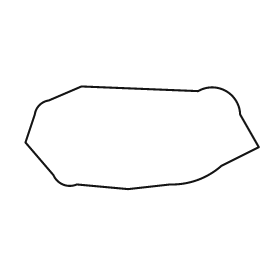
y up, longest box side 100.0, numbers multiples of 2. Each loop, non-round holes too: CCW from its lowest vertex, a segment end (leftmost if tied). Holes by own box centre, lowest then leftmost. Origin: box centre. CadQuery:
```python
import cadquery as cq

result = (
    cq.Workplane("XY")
    .moveTo(-6.0, -22.0)
    .lineTo(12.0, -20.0)
    .threePointArc((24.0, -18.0), (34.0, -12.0))
    .lineTo(50.0, -4.0)
    .lineTo(42.0, 10.0)
    .threePointArc((36.0, 20.0), (24.0, 20.0))
    .lineTo(-26.0, 22.0)
    .lineTo(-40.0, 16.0)
    .threePointArc((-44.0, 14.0), (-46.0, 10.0))
    .lineTo(-50.0, -2.0)
    .lineTo(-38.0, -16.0)
    .threePointArc((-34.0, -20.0), (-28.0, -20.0))
    .close()
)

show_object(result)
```